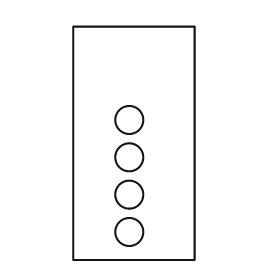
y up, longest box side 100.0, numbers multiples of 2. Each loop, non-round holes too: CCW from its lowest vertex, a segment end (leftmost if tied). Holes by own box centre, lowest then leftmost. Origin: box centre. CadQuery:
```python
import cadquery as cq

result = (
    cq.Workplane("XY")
    .moveTo(-26.0, -50.0)
    .lineTo(26.0, -50.0)
    .lineTo(26.0, 50.0)
    .lineTo(-26.0, 50.0)
    .close()
    .moveTo(-2.0, -38.0)
    .circle(6.0)
    .moveTo(-2.0, -22.0)
    .circle(6.0)
    .moveTo(-2.0, -6.0)
    .circle(6.0)
    .moveTo(-2.0, 10.0)
    .circle(6.0)
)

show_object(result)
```